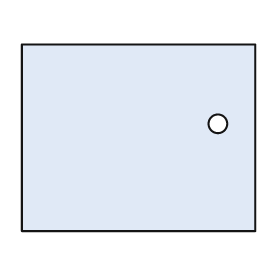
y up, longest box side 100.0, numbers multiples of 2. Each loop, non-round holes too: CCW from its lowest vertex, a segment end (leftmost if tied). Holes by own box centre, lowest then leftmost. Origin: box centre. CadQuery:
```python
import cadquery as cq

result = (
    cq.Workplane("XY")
    .moveTo(-50.0, -40.0)
    .lineTo(50.0, -40.0)
    .lineTo(50.0, 40.0)
    .lineTo(-50.0, 40.0)
    .close()
    .moveTo(34.0, 6.0)
    .circle(4.0)
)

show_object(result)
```